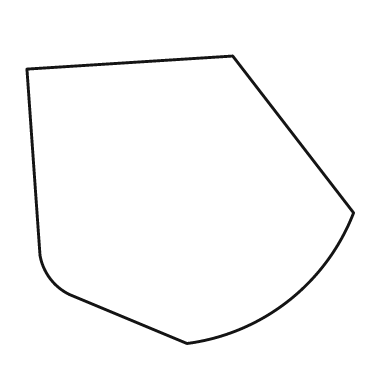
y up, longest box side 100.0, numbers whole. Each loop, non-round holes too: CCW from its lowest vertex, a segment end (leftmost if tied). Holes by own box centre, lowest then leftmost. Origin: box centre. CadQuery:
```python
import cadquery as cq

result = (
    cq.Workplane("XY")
    .moveTo(-1.0, -44.0)
    .threePointArc((30.0, -31.0), (50.0, -4.0))
    .lineTo(13.0, 44.0)
    .lineTo(-50.0, 40.0)
    .lineTo(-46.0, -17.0)
    .threePointArc((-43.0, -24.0), (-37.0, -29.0))
    .close()
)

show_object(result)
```